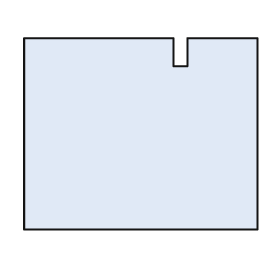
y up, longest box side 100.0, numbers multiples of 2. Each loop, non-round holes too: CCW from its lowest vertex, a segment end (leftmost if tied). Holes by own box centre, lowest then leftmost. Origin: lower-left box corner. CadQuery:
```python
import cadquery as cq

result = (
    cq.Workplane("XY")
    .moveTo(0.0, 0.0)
    .lineTo(100.0, 0.0)
    .lineTo(100.0, 82.0)
    .lineTo(70.0, 82.0)
    .lineTo(70.0, 70.0)
    .lineTo(64.0, 70.0)
    .lineTo(64.0, 82.0)
    .lineTo(0.0, 82.0)
    .close()
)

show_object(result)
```